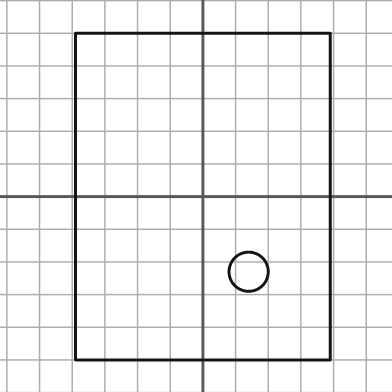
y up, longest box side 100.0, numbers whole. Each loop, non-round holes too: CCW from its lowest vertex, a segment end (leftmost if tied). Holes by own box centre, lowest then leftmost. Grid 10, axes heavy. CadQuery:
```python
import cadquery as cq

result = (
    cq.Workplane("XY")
    .moveTo(-39.0, -50.0)
    .lineTo(39.0, -50.0)
    .lineTo(39.0, 50.0)
    .lineTo(-39.0, 50.0)
    .close()
    .moveTo(14.0, -23.0)
    .circle(6.0)
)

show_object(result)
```